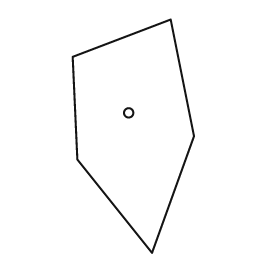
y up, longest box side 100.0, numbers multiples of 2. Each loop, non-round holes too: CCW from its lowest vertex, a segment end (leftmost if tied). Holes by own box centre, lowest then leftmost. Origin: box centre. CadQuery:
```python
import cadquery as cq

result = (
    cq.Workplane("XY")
    .moveTo(8.0, -50.0)
    .lineTo(26.0, 0.0)
    .lineTo(16.0, 50.0)
    .lineTo(-26.0, 34.0)
    .lineTo(-24.0, -10.0)
    .close()
    .moveTo(-2.0, 10.0)
    .circle(2.0)
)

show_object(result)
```